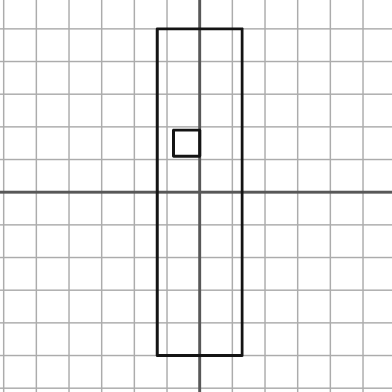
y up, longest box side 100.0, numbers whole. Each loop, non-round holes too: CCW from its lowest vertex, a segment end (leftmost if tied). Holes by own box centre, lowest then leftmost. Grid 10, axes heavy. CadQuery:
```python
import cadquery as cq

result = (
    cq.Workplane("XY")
    .moveTo(-13.0, -50.0)
    .lineTo(13.0, -50.0)
    .lineTo(13.0, 50.0)
    .lineTo(-13.0, 50.0)
    .close()
    .moveTo(-8.0, 11.0)
    .lineTo(0.0, 11.0)
    .lineTo(0.0, 19.0)
    .lineTo(-8.0, 19.0)
    .close()
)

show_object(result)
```